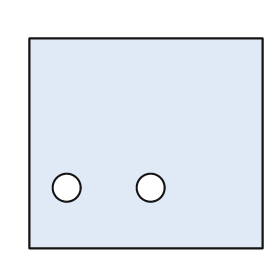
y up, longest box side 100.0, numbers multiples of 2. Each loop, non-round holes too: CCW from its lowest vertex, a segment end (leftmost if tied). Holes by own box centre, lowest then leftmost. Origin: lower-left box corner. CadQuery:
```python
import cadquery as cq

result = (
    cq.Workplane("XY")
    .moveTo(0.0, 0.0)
    .lineTo(100.0, 0.0)
    .lineTo(100.0, 90.0)
    .lineTo(0.0, 90.0)
    .close()
    .moveTo(16.0, 26.0)
    .circle(6.0)
    .moveTo(52.0, 26.0)
    .circle(6.0)
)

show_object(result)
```